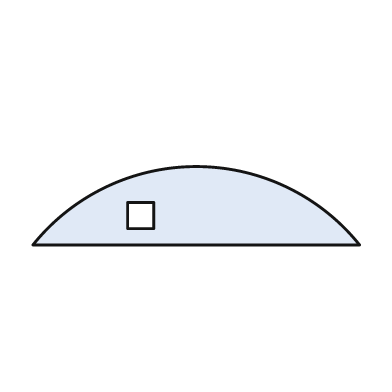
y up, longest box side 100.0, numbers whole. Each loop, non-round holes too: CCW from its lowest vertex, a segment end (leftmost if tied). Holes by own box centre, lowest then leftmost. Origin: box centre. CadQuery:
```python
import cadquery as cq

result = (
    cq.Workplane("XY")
    .moveTo(-50.0, -12.0)
    .lineTo(50.0, -12.0)
    .threePointArc((0.0, 12.0), (-50.0, -12.0))
    .close()
    .moveTo(-21.0, -7.0)
    .lineTo(-13.0, -7.0)
    .lineTo(-13.0, 1.0)
    .lineTo(-21.0, 1.0)
    .close()
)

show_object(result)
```